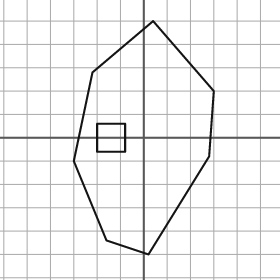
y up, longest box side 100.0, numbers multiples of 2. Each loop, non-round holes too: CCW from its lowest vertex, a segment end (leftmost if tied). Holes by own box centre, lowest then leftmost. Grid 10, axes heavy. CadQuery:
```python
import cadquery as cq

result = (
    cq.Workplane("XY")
    .moveTo(2.0, -50.0)
    .lineTo(28.0, -8.0)
    .lineTo(30.0, 20.0)
    .lineTo(4.0, 50.0)
    .lineTo(-22.0, 28.0)
    .lineTo(-30.0, -10.0)
    .lineTo(-16.0, -44.0)
    .close()
    .moveTo(-20.0, -6.0)
    .lineTo(-8.0, -6.0)
    .lineTo(-8.0, 6.0)
    .lineTo(-20.0, 6.0)
    .close()
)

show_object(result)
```